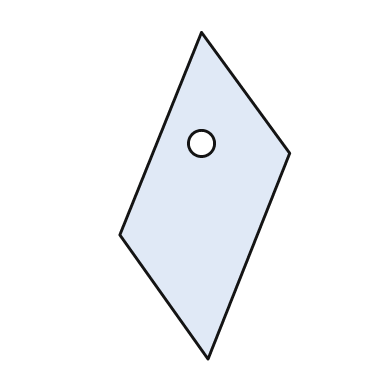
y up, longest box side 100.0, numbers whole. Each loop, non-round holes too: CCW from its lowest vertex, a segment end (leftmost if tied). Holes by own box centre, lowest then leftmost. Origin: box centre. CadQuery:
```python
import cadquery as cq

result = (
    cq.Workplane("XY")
    .moveTo(1.0, -50.0)
    .lineTo(26.0, 13.0)
    .lineTo(-1.0, 50.0)
    .lineTo(-26.0, -12.0)
    .close()
    .moveTo(-1.0, 16.0)
    .circle(4.0)
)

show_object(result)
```